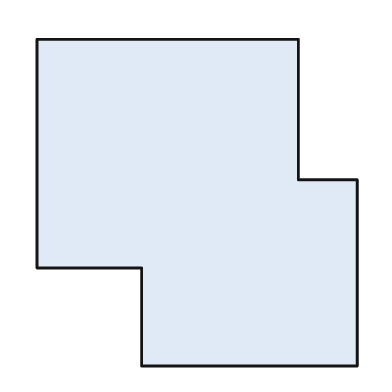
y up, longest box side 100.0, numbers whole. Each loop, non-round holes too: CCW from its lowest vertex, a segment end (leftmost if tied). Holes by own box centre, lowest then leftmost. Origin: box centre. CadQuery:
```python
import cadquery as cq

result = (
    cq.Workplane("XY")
    .moveTo(-17.0, -50.0)
    .lineTo(49.0, -50.0)
    .lineTo(49.0, 7.0)
    .lineTo(31.0, 7.0)
    .lineTo(31.0, 50.0)
    .lineTo(-49.0, 50.0)
    .lineTo(-49.0, -20.0)
    .lineTo(-17.0, -20.0)
    .close()
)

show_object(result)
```